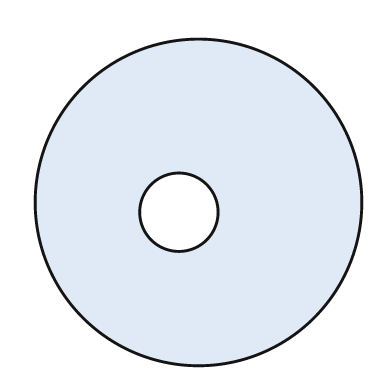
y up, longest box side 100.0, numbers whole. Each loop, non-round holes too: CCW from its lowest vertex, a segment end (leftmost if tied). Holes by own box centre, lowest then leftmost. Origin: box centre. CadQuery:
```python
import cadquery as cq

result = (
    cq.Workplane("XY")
    .moveTo(0.0, 0.0)
    .circle(50.0)
    .moveTo(-6.0, -3.0)
    .circle(12.0)
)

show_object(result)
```